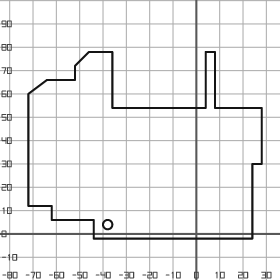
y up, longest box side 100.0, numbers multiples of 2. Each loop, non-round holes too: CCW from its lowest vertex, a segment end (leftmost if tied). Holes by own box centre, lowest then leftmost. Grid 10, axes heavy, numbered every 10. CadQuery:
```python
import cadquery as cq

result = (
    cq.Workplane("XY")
    .moveTo(-44.0, -2.0)
    .lineTo(24.0, -2.0)
    .lineTo(24.0, 30.0)
    .lineTo(28.0, 30.0)
    .lineTo(28.0, 54.0)
    .lineTo(8.0, 54.0)
    .lineTo(8.0, 78.0)
    .lineTo(4.0, 78.0)
    .lineTo(4.0, 54.0)
    .lineTo(-36.0, 54.0)
    .lineTo(-36.0, 78.0)
    .lineTo(-46.0, 78.0)
    .lineTo(-52.0, 72.0)
    .lineTo(-52.0, 66.0)
    .lineTo(-64.0, 66.0)
    .lineTo(-72.0, 60.0)
    .lineTo(-72.0, 12.0)
    .lineTo(-62.0, 12.0)
    .lineTo(-62.0, 6.0)
    .lineTo(-44.0, 6.0)
    .close()
    .moveTo(-38.0, 4.0)
    .circle(2.0)
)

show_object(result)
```